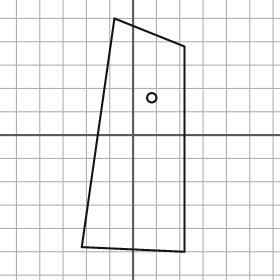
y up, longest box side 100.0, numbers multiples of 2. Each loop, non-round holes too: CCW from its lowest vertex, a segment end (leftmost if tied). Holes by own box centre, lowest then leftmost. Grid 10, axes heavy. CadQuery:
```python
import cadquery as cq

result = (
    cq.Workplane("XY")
    .moveTo(22.0, -50.0)
    .lineTo(22.0, 38.0)
    .lineTo(-8.0, 50.0)
    .lineTo(-22.0, -48.0)
    .close()
    .moveTo(8.0, 16.0)
    .circle(2.0)
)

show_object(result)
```